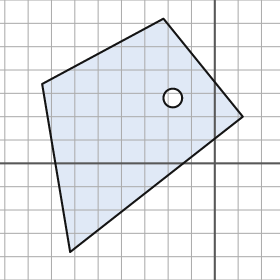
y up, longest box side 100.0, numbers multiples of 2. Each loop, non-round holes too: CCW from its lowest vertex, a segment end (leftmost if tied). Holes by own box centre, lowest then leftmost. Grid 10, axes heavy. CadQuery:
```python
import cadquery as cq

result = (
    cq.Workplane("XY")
    .moveTo(-62.0, -38.0)
    .lineTo(12.0, 20.0)
    .lineTo(-22.0, 62.0)
    .lineTo(-74.0, 34.0)
    .close()
    .moveTo(-18.0, 28.0)
    .circle(4.0)
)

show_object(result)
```